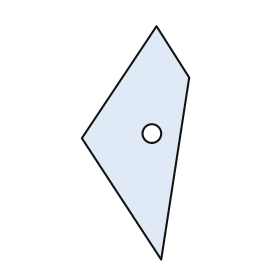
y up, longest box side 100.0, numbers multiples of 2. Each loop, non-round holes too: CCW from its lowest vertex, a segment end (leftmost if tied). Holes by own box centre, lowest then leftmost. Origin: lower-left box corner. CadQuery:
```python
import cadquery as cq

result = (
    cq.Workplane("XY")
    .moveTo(34.0, 0.0)
    .lineTo(46.0, 78.0)
    .lineTo(32.0, 100.0)
    .lineTo(0.0, 52.0)
    .close()
    .moveTo(30.0, 54.0)
    .circle(4.0)
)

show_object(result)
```